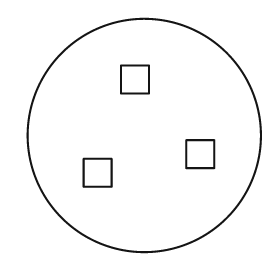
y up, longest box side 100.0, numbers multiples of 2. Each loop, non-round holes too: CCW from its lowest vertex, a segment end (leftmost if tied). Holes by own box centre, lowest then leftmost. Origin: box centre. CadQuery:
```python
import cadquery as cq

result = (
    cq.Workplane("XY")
    .moveTo(0.0, 0.0)
    .circle(50.0)
    .moveTo(-26.0, -22.0)
    .lineTo(-14.0, -22.0)
    .lineTo(-14.0, -10.0)
    .lineTo(-26.0, -10.0)
    .close()
    .moveTo(18.0, -14.0)
    .lineTo(30.0, -14.0)
    .lineTo(30.0, -2.0)
    .lineTo(18.0, -2.0)
    .close()
    .moveTo(-10.0, 18.0)
    .lineTo(2.0, 18.0)
    .lineTo(2.0, 30.0)
    .lineTo(-10.0, 30.0)
    .close()
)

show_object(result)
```